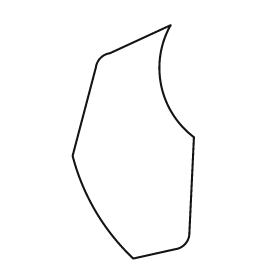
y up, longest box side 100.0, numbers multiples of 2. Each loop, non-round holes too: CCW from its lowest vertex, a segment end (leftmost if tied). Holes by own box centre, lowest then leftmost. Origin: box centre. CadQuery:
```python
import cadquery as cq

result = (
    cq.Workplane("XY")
    .moveTo(0.0, -50.0)
    .lineTo(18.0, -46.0)
    .threePointArc((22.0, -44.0), (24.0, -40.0))
    .lineTo(26.0, 2.0)
    .threePointArc((12.0, 24.0), (16.0, 50.0))
    .lineTo(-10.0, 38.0)
    .threePointArc((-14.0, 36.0), (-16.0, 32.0))
    .lineTo(-26.0, -6.0)
    .threePointArc((-16.0, -30.0), (0.0, -50.0))
    .close()
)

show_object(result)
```